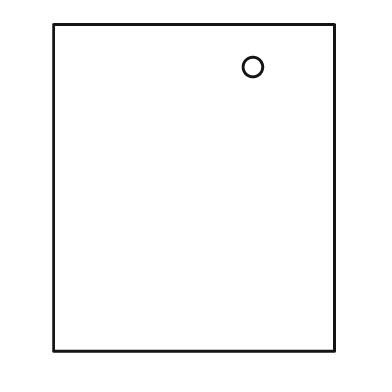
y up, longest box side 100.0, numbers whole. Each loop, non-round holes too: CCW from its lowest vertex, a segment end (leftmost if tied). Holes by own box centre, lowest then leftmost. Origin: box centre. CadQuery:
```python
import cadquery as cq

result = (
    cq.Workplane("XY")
    .moveTo(-43.0, -50.0)
    .lineTo(43.0, -50.0)
    .lineTo(43.0, 50.0)
    .lineTo(-43.0, 50.0)
    .close()
    .moveTo(18.0, 37.0)
    .circle(3.0)
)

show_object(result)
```